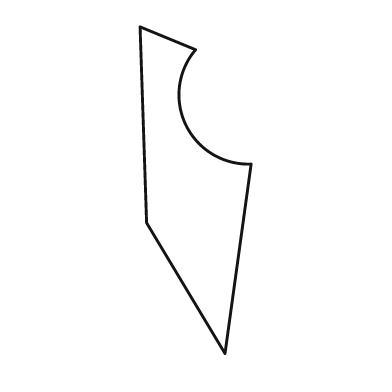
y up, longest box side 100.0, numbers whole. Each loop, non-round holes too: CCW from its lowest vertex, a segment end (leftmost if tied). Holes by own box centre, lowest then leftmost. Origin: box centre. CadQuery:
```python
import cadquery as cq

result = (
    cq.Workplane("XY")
    .moveTo(9.0, -50.0)
    .lineTo(17.0, 8.0)
    .threePointArc((-3.0, 20.0), (0.0, 43.0))
    .lineTo(-17.0, 50.0)
    .lineTo(-15.0, -10.0)
    .close()
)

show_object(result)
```